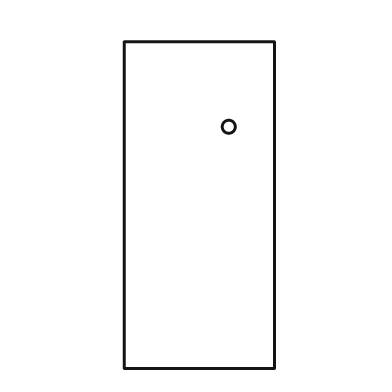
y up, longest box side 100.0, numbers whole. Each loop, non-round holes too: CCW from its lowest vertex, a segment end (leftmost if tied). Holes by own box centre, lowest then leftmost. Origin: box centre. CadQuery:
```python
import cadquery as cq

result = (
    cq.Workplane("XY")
    .moveTo(-23.0, -50.0)
    .lineTo(23.0, -50.0)
    .lineTo(23.0, 50.0)
    .lineTo(-23.0, 50.0)
    .close()
    .moveTo(9.0, 24.0)
    .circle(2.0)
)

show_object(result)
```